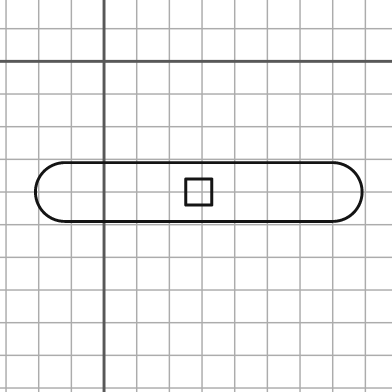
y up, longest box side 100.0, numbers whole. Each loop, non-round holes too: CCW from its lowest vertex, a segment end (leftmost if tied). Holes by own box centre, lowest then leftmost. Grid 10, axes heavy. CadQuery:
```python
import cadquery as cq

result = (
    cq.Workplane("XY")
    .moveTo(-12.0, -49.0)
    .lineTo(70.0, -49.0)
    .threePointArc((79.0, -40.0), (70.0, -31.0))
    .lineTo(-12.0, -31.0)
    .threePointArc((-21.0, -40.0), (-12.0, -49.0))
    .close()
    .moveTo(25.0, -44.0)
    .lineTo(33.0, -44.0)
    .lineTo(33.0, -36.0)
    .lineTo(25.0, -36.0)
    .close()
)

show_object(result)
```